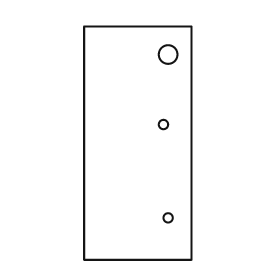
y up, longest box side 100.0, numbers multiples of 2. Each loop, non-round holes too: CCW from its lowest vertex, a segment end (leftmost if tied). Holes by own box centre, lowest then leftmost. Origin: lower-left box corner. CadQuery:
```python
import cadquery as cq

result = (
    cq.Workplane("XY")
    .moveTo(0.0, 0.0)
    .lineTo(46.0, 0.0)
    .lineTo(46.0, 100.0)
    .lineTo(0.0, 100.0)
    .close()
    .moveTo(36.0, 18.0)
    .circle(2.0)
    .moveTo(34.0, 58.0)
    .circle(2.0)
    .moveTo(36.0, 88.0)
    .circle(4.0)
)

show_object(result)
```